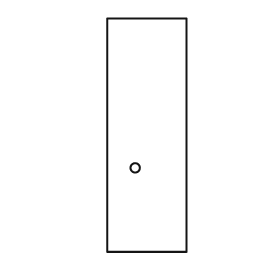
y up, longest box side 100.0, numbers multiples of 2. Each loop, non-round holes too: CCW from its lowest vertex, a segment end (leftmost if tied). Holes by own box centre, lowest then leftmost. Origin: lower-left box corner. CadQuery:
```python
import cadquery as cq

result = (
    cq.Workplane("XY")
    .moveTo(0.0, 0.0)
    .lineTo(34.0, 0.0)
    .lineTo(34.0, 100.0)
    .lineTo(0.0, 100.0)
    .close()
    .moveTo(12.0, 36.0)
    .circle(2.0)
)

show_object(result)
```